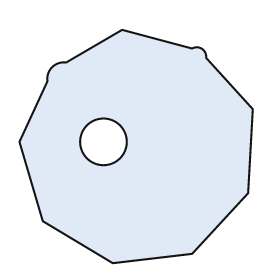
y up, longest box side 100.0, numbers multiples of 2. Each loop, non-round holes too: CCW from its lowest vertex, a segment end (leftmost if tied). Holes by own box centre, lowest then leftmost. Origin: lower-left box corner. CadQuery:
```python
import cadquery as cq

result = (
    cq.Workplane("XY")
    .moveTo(40.0, 0.0)
    .lineTo(74.0, 4.0)
    .lineTo(98.0, 30.0)
    .lineTo(100.0, 66.0)
    .lineTo(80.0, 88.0)
    .threePointArc((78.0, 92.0), (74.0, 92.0))
    .lineTo(44.0, 100.0)
    .lineTo(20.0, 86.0)
    .threePointArc((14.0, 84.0), (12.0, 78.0))
    .lineTo(0.0, 52.0)
    .lineTo(10.0, 18.0)
    .close()
    .moveTo(36.0, 52.0)
    .circle(10.0)
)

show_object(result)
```